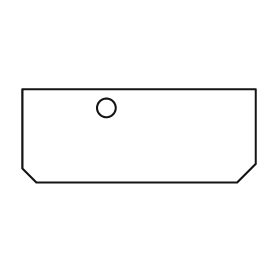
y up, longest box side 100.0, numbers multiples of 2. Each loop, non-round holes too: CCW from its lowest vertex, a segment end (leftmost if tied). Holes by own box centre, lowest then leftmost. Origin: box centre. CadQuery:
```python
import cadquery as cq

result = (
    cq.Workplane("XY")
    .moveTo(-44.0, -20.0)
    .lineTo(42.0, -20.0)
    .lineTo(50.0, -12.0)
    .lineTo(50.0, 20.0)
    .lineTo(-50.0, 20.0)
    .lineTo(-50.0, -14.0)
    .close()
    .moveTo(-14.0, 12.0)
    .circle(4.0)
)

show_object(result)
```